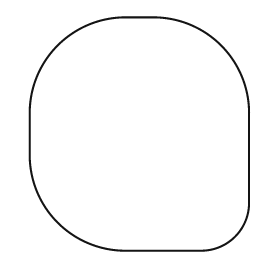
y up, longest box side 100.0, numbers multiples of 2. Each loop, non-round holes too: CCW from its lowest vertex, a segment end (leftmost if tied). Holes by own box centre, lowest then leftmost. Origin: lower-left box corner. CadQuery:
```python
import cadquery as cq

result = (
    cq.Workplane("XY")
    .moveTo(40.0, 0.0)
    .lineTo(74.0, 0.0)
    .threePointArc((88.0, 6.0), (94.0, 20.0))
    .lineTo(94.0, 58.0)
    .threePointArc((82.0, 88.0), (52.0, 100.0))
    .lineTo(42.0, 100.0)
    .threePointArc((12.0, 88.0), (0.0, 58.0))
    .lineTo(0.0, 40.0)
    .threePointArc((12.0, 12.0), (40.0, 0.0))
    .close()
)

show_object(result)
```